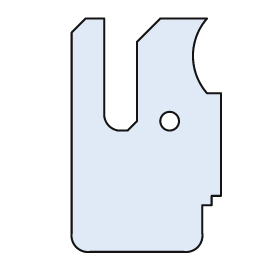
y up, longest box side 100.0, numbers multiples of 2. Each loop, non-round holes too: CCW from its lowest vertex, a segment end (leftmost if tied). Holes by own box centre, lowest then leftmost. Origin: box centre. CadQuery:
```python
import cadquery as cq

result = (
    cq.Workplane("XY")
    .moveTo(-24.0, -50.0)
    .lineTo(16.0, -50.0)
    .threePointArc((22.0, -48.0), (24.0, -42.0))
    .lineTo(24.0, -30.0)
    .lineTo(28.0, -30.0)
    .lineTo(28.0, -26.0)
    .lineTo(32.0, -26.0)
    .lineTo(32.0, 18.0)
    .lineTo(26.0, 18.0)
    .threePointArc((20.0, 34.0), (26.0, 50.0))
    .lineTo(6.0, 50.0)
    .lineTo(-4.0, 40.0)
    .lineTo(-4.0, 6.0)
    .lineTo(-8.0, 2.0)
    .lineTo(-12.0, 2.0)
    .threePointArc((-16.0, 4.0), (-18.0, 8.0))
    .lineTo(-18.0, 50.0)
    .lineTo(-26.0, 50.0)
    .lineTo(-32.0, 44.0)
    .lineTo(-32.0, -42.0)
    .threePointArc((-30.0, -48.0), (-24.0, -50.0))
    .close()
    .moveTo(10.0, 6.0)
    .circle(4.0)
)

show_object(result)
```